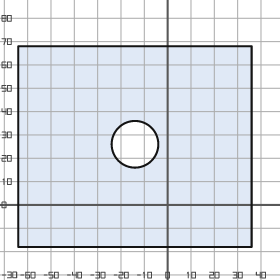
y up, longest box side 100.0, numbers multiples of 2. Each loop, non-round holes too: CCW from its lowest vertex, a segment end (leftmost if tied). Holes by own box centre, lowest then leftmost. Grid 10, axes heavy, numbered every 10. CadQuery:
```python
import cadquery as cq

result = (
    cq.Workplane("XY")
    .moveTo(-64.0, -18.0)
    .lineTo(36.0, -18.0)
    .lineTo(36.0, 68.0)
    .lineTo(-64.0, 68.0)
    .close()
    .moveTo(-14.0, 26.0)
    .circle(10.0)
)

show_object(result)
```